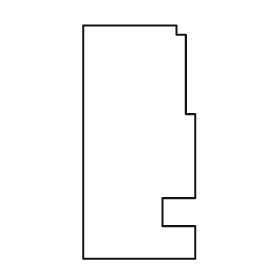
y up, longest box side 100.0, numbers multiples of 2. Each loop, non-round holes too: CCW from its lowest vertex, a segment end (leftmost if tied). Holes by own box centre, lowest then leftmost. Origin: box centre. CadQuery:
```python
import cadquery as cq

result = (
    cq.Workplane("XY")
    .moveTo(-24.0, -50.0)
    .lineTo(24.0, -50.0)
    .lineTo(24.0, -36.0)
    .lineTo(10.0, -36.0)
    .lineTo(10.0, -24.0)
    .lineTo(24.0, -24.0)
    .lineTo(24.0, 12.0)
    .lineTo(20.0, 12.0)
    .lineTo(20.0, 46.0)
    .lineTo(16.0, 46.0)
    .lineTo(16.0, 50.0)
    .lineTo(-24.0, 50.0)
    .close()
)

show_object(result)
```